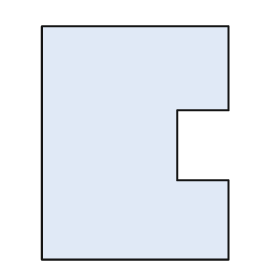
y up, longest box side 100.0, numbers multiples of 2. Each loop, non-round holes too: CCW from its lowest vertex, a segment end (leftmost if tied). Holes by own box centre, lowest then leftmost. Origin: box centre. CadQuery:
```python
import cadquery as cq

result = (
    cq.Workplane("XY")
    .moveTo(-40.0, -50.0)
    .lineTo(40.0, -50.0)
    .lineTo(40.0, -16.0)
    .lineTo(18.0, -16.0)
    .lineTo(18.0, 14.0)
    .lineTo(40.0, 14.0)
    .lineTo(40.0, 50.0)
    .lineTo(-40.0, 50.0)
    .close()
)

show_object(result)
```